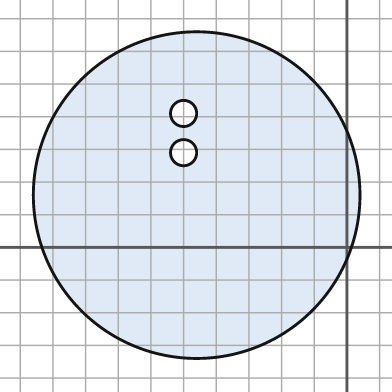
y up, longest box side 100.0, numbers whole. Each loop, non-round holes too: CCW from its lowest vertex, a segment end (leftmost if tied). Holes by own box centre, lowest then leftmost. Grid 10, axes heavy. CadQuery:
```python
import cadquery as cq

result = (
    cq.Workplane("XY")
    .moveTo(-46.0, 16.0)
    .circle(50.0)
    .moveTo(-50.0, 29.0)
    .circle(4.0)
    .moveTo(-50.0, 41.0)
    .circle(4.0)
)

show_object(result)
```